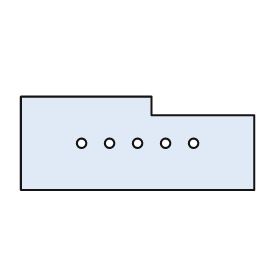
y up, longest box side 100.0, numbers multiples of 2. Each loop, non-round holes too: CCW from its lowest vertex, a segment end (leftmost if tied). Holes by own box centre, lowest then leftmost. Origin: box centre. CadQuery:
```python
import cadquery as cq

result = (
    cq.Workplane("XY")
    .moveTo(-50.0, -20.0)
    .lineTo(50.0, -20.0)
    .lineTo(50.0, 12.0)
    .lineTo(6.0, 12.0)
    .lineTo(6.0, 20.0)
    .lineTo(-50.0, 20.0)
    .close()
    .moveTo(-24.0, 0.0)
    .circle(2.0)
    .moveTo(-12.0, 0.0)
    .circle(2.0)
    .moveTo(0.0, 0.0)
    .circle(2.0)
    .moveTo(12.0, 0.0)
    .circle(2.0)
    .moveTo(24.0, 0.0)
    .circle(2.0)
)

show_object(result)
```